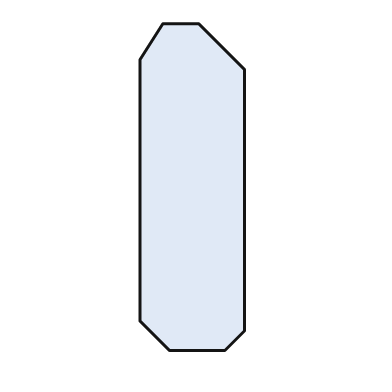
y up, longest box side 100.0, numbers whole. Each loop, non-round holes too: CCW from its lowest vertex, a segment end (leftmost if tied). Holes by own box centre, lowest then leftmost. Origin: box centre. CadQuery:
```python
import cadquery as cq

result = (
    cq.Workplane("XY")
    .moveTo(-7.0, -50.0)
    .lineTo(10.0, -50.0)
    .lineTo(16.0, -44.0)
    .lineTo(16.0, 36.0)
    .lineTo(2.0, 50.0)
    .lineTo(-9.0, 50.0)
    .lineTo(-16.0, 39.0)
    .lineTo(-16.0, -41.0)
    .close()
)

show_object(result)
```